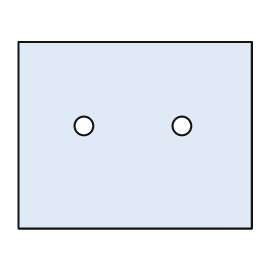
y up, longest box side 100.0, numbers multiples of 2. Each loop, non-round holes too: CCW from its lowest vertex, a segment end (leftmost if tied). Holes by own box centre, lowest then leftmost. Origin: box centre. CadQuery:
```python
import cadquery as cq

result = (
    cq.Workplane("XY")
    .moveTo(-50.0, -40.0)
    .lineTo(50.0, -40.0)
    .lineTo(50.0, 40.0)
    .lineTo(-50.0, 40.0)
    .close()
    .moveTo(-22.0, 4.0)
    .circle(4.0)
    .moveTo(20.0, 4.0)
    .circle(4.0)
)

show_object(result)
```